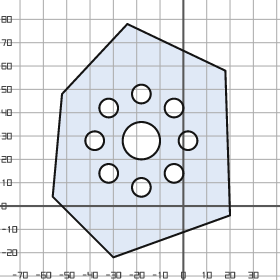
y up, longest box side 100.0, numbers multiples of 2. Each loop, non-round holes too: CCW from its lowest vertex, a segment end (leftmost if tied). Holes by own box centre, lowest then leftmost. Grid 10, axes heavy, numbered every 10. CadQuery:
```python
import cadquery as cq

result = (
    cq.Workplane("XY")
    .moveTo(-30.0, -22.0)
    .lineTo(20.0, -4.0)
    .lineTo(18.0, 58.0)
    .lineTo(-24.0, 78.0)
    .lineTo(-52.0, 48.0)
    .lineTo(-56.0, 4.0)
    .close()
    .moveTo(-18.0, 8.0)
    .circle(4.0)
    .moveTo(-32.0, 14.0)
    .circle(4.0)
    .moveTo(-4.0, 14.0)
    .circle(4.0)
    .moveTo(-38.0, 28.0)
    .circle(4.0)
    .moveTo(-18.0, 28.0)
    .circle(8.0)
    .moveTo(2.0, 28.0)
    .circle(4.0)
    .moveTo(-32.0, 42.0)
    .circle(4.0)
    .moveTo(-4.0, 42.0)
    .circle(4.0)
    .moveTo(-18.0, 48.0)
    .circle(4.0)
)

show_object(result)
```